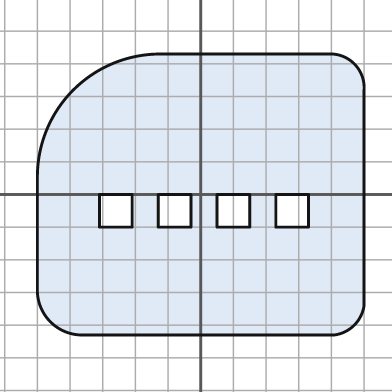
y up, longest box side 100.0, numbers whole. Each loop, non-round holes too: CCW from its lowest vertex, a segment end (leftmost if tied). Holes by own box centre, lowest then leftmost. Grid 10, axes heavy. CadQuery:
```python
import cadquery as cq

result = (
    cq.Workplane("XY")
    .moveTo(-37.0, -43.0)
    .lineTo(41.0, -43.0)
    .threePointArc((47.0, -40.0), (50.0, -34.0))
    .lineTo(50.0, 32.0)
    .threePointArc((47.0, 40.0), (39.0, 43.0))
    .lineTo(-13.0, 43.0)
    .threePointArc((-39.0, 32.0), (-50.0, 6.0))
    .lineTo(-50.0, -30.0)
    .threePointArc((-46.0, -39.0), (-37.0, -43.0))
    .close()
    .moveTo(-31.0, -10.0)
    .lineTo(-21.0, -10.0)
    .lineTo(-21.0, 0.0)
    .lineTo(-31.0, 0.0)
    .close()
    .moveTo(-13.0, -10.0)
    .lineTo(-3.0, -10.0)
    .lineTo(-3.0, 0.0)
    .lineTo(-13.0, 0.0)
    .close()
    .moveTo(5.0, -10.0)
    .lineTo(15.0, -10.0)
    .lineTo(15.0, 0.0)
    .lineTo(5.0, 0.0)
    .close()
    .moveTo(23.0, -10.0)
    .lineTo(33.0, -10.0)
    .lineTo(33.0, 0.0)
    .lineTo(23.0, 0.0)
    .close()
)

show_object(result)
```